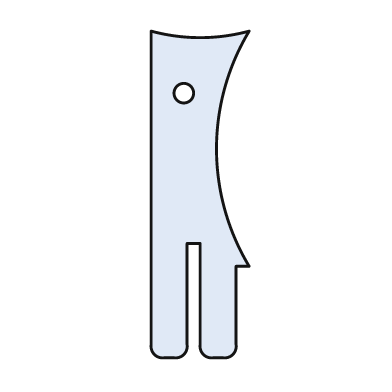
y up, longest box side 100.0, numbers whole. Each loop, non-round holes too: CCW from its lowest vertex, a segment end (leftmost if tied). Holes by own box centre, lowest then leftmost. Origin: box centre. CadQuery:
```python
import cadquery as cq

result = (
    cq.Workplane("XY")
    .moveTo(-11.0, -50.0)
    .lineTo(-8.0, -50.0)
    .threePointArc((-5.0, -49.0), (-4.0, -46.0))
    .lineTo(-4.0, -15.0)
    .lineTo(0.0, -15.0)
    .lineTo(0.0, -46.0)
    .threePointArc((1.0, -49.0), (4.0, -50.0))
    .lineTo(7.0, -50.0)
    .threePointArc((10.0, -49.0), (11.0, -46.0))
    .lineTo(11.0, -22.0)
    .lineTo(15.0, -22.0)
    .threePointArc((5.0, 14.0), (15.0, 50.0))
    .threePointArc((0.0, 48.0), (-15.0, 50.0))
    .lineTo(-15.0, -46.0)
    .threePointArc((-14.0, -49.0), (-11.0, -50.0))
    .close()
    .moveTo(-5.0, 31.0)
    .circle(3.0)
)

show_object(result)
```